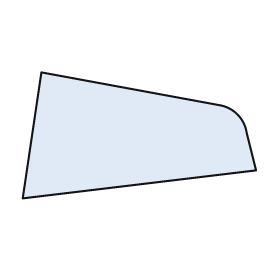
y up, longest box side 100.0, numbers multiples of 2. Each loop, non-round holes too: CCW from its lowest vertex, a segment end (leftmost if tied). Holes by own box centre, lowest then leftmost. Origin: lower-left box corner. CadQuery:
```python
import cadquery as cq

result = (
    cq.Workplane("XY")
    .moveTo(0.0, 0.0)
    .lineTo(100.0, 12.0)
    .lineTo(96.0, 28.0)
    .threePointArc((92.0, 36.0), (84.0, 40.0))
    .lineTo(8.0, 54.0)
    .close()
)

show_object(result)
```